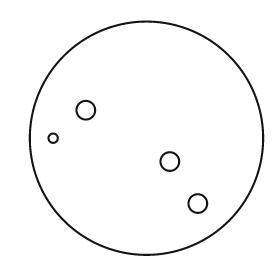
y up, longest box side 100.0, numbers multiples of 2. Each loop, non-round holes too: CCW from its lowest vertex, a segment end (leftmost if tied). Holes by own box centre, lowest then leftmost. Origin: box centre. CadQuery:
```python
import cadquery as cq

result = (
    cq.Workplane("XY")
    .moveTo(0.0, 0.0)
    .circle(50.0)
    .moveTo(22.0, -28.0)
    .circle(4.0)
    .moveTo(10.0, -10.0)
    .circle(4.0)
    .moveTo(-40.0, 0.0)
    .circle(2.0)
    .moveTo(-26.0, 12.0)
    .circle(4.0)
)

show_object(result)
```